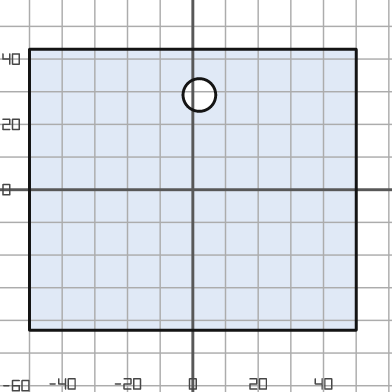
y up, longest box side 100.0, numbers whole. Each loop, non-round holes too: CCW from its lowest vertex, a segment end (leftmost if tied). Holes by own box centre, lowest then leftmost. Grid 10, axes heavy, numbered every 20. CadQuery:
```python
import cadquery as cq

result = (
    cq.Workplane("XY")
    .moveTo(-50.0, -43.0)
    .lineTo(50.0, -43.0)
    .lineTo(50.0, 43.0)
    .lineTo(-50.0, 43.0)
    .close()
    .moveTo(2.0, 29.0)
    .circle(5.0)
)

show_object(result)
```